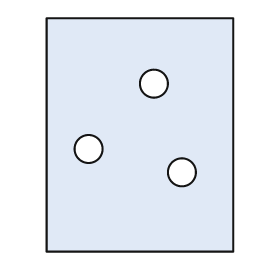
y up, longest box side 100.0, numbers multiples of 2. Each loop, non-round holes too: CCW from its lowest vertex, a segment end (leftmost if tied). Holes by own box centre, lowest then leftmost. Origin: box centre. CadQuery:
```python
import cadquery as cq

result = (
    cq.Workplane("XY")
    .moveTo(-40.0, -50.0)
    .lineTo(40.0, -50.0)
    .lineTo(40.0, 50.0)
    .lineTo(-40.0, 50.0)
    .close()
    .moveTo(18.0, -16.0)
    .circle(6.0)
    .moveTo(-22.0, -6.0)
    .circle(6.0)
    .moveTo(6.0, 22.0)
    .circle(6.0)
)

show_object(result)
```